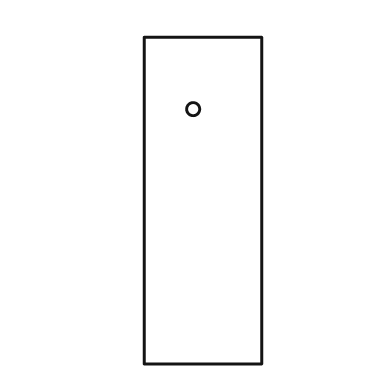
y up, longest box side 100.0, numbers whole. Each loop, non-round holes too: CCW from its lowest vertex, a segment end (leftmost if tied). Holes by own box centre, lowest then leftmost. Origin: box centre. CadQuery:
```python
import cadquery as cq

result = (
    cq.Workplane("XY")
    .moveTo(-18.0, -50.0)
    .lineTo(18.0, -50.0)
    .lineTo(18.0, 50.0)
    .lineTo(-18.0, 50.0)
    .close()
    .moveTo(-3.0, 28.0)
    .circle(2.0)
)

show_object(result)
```